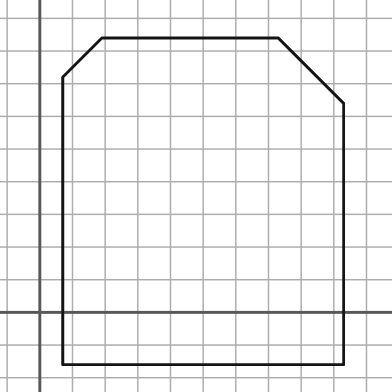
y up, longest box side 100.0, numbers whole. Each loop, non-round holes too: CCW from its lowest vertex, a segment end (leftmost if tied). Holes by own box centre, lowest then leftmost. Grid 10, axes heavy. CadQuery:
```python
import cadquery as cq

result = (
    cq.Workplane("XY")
    .moveTo(7.0, -16.0)
    .lineTo(93.0, -16.0)
    .lineTo(93.0, 64.0)
    .lineTo(73.0, 84.0)
    .lineTo(19.0, 84.0)
    .lineTo(7.0, 72.0)
    .close()
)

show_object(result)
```